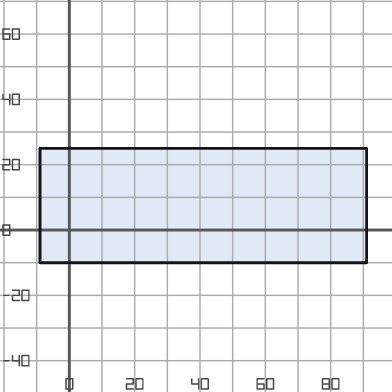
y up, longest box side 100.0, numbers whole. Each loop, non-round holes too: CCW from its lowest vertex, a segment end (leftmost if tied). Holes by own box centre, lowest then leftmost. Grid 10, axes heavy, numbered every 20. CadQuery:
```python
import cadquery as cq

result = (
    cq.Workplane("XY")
    .moveTo(-9.0, -10.0)
    .lineTo(91.0, -10.0)
    .lineTo(91.0, 25.0)
    .lineTo(-9.0, 25.0)
    .close()
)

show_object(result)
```